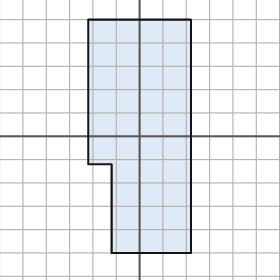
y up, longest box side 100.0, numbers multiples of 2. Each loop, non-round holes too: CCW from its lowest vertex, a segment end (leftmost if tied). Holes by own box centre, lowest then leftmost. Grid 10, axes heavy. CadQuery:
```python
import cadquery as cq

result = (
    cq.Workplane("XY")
    .moveTo(-12.0, -50.0)
    .lineTo(22.0, -50.0)
    .lineTo(22.0, 50.0)
    .lineTo(-22.0, 50.0)
    .lineTo(-22.0, -12.0)
    .lineTo(-12.0, -12.0)
    .close()
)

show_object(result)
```